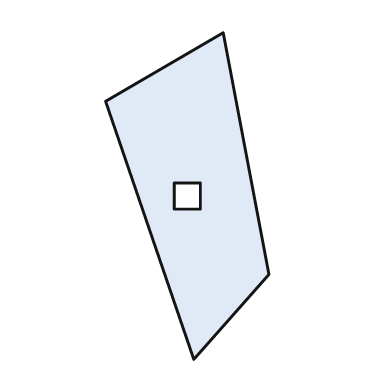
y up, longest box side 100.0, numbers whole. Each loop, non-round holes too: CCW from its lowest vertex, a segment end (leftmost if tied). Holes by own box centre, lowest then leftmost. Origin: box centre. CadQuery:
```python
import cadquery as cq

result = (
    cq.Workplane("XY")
    .moveTo(2.0, -50.0)
    .lineTo(25.0, -24.0)
    .lineTo(11.0, 50.0)
    .lineTo(-25.0, 29.0)
    .close()
    .moveTo(-4.0, -4.0)
    .lineTo(4.0, -4.0)
    .lineTo(4.0, 4.0)
    .lineTo(-4.0, 4.0)
    .close()
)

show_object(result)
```